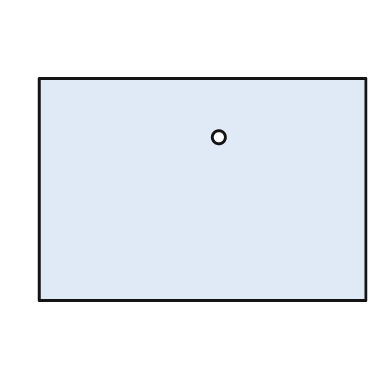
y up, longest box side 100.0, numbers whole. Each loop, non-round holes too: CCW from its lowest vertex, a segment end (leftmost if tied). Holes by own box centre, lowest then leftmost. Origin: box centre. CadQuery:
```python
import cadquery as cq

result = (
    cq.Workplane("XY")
    .moveTo(-50.0, -34.0)
    .lineTo(50.0, -34.0)
    .lineTo(50.0, 34.0)
    .lineTo(-50.0, 34.0)
    .close()
    .moveTo(5.0, 16.0)
    .circle(2.0)
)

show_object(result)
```